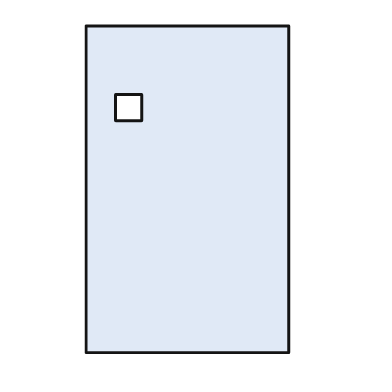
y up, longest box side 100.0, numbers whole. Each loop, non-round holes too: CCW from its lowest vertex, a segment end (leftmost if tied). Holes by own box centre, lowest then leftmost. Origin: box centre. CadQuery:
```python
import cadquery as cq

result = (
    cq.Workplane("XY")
    .moveTo(-31.0, -50.0)
    .lineTo(31.0, -50.0)
    .lineTo(31.0, 50.0)
    .lineTo(-31.0, 50.0)
    .close()
    .moveTo(-22.0, 21.0)
    .lineTo(-14.0, 21.0)
    .lineTo(-14.0, 29.0)
    .lineTo(-22.0, 29.0)
    .close()
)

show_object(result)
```